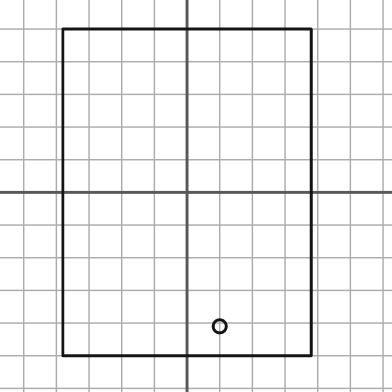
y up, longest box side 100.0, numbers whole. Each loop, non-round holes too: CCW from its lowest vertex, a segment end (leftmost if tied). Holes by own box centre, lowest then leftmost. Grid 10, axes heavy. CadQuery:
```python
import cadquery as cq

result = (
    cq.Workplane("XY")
    .moveTo(-38.0, -50.0)
    .lineTo(38.0, -50.0)
    .lineTo(38.0, 50.0)
    .lineTo(-38.0, 50.0)
    .close()
    .moveTo(10.0, -41.0)
    .circle(2.0)
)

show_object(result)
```